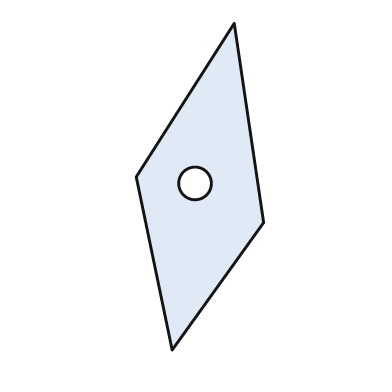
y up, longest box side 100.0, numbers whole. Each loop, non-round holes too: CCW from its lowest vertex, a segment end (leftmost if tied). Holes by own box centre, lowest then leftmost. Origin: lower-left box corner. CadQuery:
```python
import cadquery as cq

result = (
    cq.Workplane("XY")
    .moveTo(11.0, 0.0)
    .lineTo(39.0, 39.0)
    .lineTo(30.0, 100.0)
    .lineTo(0.0, 53.0)
    .close()
    .moveTo(18.0, 51.0)
    .circle(5.0)
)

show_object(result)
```